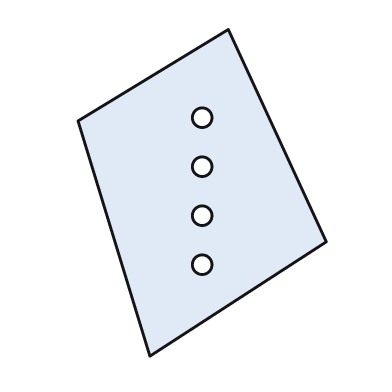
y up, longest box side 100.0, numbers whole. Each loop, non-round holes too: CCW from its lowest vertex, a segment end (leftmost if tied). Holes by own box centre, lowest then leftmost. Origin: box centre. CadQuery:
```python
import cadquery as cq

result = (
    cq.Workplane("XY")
    .moveTo(-16.0, -50.0)
    .lineTo(38.0, -15.0)
    .lineTo(8.0, 50.0)
    .lineTo(-38.0, 22.0)
    .close()
    .moveTo(0.0, -22.0)
    .circle(3.0)
    .moveTo(0.0, -7.0)
    .circle(3.0)
    .moveTo(0.0, 8.0)
    .circle(3.0)
    .moveTo(0.0, 23.0)
    .circle(3.0)
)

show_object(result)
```